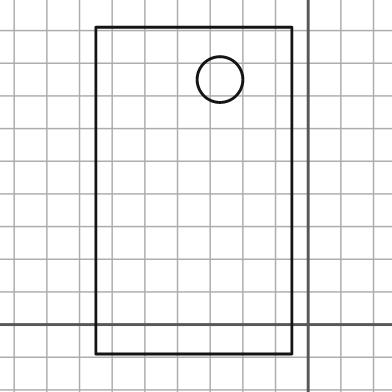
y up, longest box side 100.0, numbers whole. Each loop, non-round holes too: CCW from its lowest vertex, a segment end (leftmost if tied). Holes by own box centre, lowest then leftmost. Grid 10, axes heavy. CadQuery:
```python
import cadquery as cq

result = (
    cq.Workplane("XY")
    .moveTo(-65.0, -9.0)
    .lineTo(-5.0, -9.0)
    .lineTo(-5.0, 91.0)
    .lineTo(-65.0, 91.0)
    .close()
    .moveTo(-27.0, 75.0)
    .circle(7.0)
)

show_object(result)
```